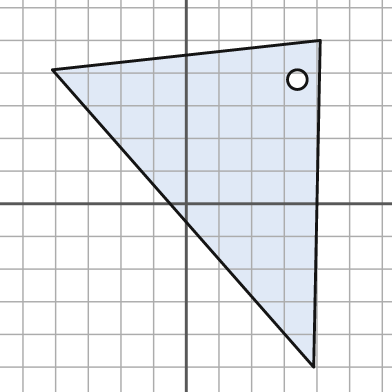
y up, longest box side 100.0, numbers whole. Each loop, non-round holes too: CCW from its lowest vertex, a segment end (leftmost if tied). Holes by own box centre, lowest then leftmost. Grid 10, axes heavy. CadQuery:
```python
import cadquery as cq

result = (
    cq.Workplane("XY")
    .moveTo(39.0, -50.0)
    .lineTo(41.0, 50.0)
    .lineTo(-41.0, 41.0)
    .close()
    .moveTo(34.0, 38.0)
    .circle(3.0)
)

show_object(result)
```